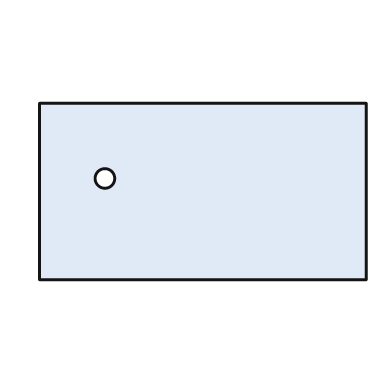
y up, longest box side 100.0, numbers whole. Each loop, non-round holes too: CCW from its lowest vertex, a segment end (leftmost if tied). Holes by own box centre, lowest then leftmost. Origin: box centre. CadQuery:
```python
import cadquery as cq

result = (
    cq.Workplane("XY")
    .moveTo(-50.0, -27.0)
    .lineTo(50.0, -27.0)
    .lineTo(50.0, 27.0)
    .lineTo(-50.0, 27.0)
    .close()
    .moveTo(-30.0, 4.0)
    .circle(3.0)
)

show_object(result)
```